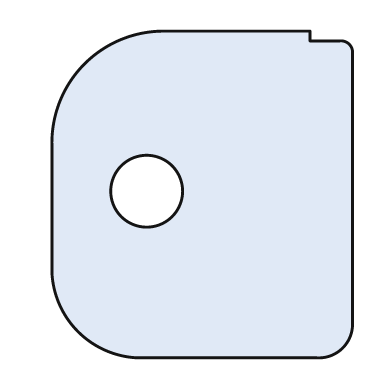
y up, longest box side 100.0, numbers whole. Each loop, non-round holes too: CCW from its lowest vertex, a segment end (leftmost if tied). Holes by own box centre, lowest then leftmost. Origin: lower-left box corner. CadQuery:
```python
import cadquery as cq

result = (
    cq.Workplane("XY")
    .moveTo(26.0, 0.0)
    .lineTo(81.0, 0.0)
    .threePointArc((89.0, 3.0), (92.0, 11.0))
    .lineTo(92.0, 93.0)
    .threePointArc((91.0, 96.0), (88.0, 97.0))
    .lineTo(79.0, 97.0)
    .lineTo(79.0, 100.0)
    .lineTo(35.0, 100.0)
    .threePointArc((10.0, 90.0), (0.0, 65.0))
    .lineTo(0.0, 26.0)
    .threePointArc((8.0, 8.0), (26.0, 0.0))
    .close()
    .moveTo(29.0, 51.0)
    .circle(11.0)
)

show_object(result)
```